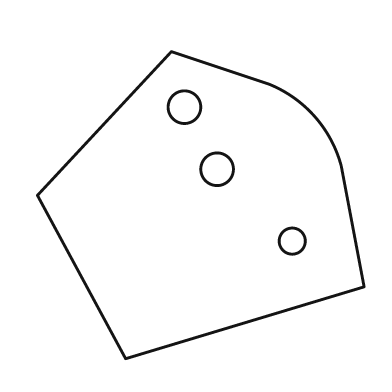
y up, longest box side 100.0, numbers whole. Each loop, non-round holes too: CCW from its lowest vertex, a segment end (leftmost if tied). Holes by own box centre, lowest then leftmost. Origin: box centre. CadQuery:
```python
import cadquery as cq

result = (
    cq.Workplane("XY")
    .moveTo(-23.0, -47.0)
    .lineTo(50.0, -25.0)
    .lineTo(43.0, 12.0)
    .threePointArc((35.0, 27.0), (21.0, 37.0))
    .lineTo(-9.0, 47.0)
    .lineTo(-50.0, 3.0)
    .close()
    .moveTo(28.0, -11.0)
    .circle(4.0)
    .moveTo(5.0, 11.0)
    .circle(5.0)
    .moveTo(-5.0, 30.0)
    .circle(5.0)
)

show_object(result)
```